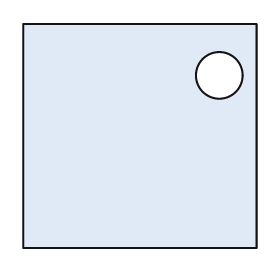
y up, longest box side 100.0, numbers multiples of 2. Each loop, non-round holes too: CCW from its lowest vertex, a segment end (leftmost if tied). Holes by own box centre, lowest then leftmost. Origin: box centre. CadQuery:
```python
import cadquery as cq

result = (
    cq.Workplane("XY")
    .moveTo(-50.0, -48.0)
    .lineTo(50.0, -48.0)
    .lineTo(50.0, 48.0)
    .lineTo(-50.0, 48.0)
    .close()
    .moveTo(34.0, 26.0)
    .circle(10.0)
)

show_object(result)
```